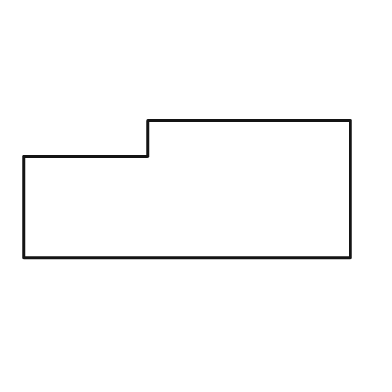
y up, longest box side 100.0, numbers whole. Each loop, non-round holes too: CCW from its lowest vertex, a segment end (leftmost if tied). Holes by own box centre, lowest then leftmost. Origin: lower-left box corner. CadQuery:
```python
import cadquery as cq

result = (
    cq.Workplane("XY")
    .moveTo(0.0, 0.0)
    .lineTo(100.0, 0.0)
    .lineTo(100.0, 42.0)
    .lineTo(38.0, 42.0)
    .lineTo(38.0, 31.0)
    .lineTo(0.0, 31.0)
    .close()
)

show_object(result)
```